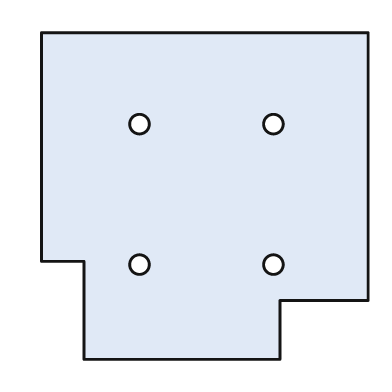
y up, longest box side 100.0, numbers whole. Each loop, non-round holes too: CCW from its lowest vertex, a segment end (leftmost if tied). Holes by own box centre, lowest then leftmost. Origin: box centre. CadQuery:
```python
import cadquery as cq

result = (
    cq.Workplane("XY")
    .moveTo(-37.0, -50.0)
    .lineTo(23.0, -50.0)
    .lineTo(23.0, -32.0)
    .lineTo(50.0, -32.0)
    .lineTo(50.0, 50.0)
    .lineTo(-50.0, 50.0)
    .lineTo(-50.0, -20.0)
    .lineTo(-37.0, -20.0)
    .close()
    .moveTo(-20.0, -21.0)
    .circle(3.0)
    .moveTo(21.0, -21.0)
    .circle(3.0)
    .moveTo(-20.0, 22.0)
    .circle(3.0)
    .moveTo(21.0, 22.0)
    .circle(3.0)
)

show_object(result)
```